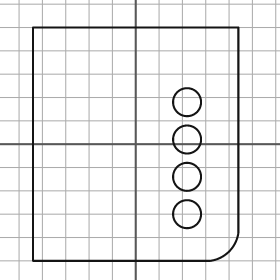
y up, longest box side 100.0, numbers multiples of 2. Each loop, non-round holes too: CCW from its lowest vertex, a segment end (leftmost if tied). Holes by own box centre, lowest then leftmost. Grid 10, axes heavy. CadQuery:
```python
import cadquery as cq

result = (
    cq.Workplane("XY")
    .moveTo(-44.0, -50.0)
    .lineTo(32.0, -50.0)
    .threePointArc((40.0, -46.0), (44.0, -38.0))
    .lineTo(44.0, 50.0)
    .lineTo(-44.0, 50.0)
    .close()
    .moveTo(22.0, -30.0)
    .circle(6.0)
    .moveTo(22.0, -14.0)
    .circle(6.0)
    .moveTo(22.0, 2.0)
    .circle(6.0)
    .moveTo(22.0, 18.0)
    .circle(6.0)
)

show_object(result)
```